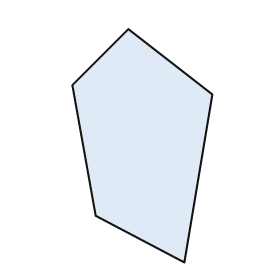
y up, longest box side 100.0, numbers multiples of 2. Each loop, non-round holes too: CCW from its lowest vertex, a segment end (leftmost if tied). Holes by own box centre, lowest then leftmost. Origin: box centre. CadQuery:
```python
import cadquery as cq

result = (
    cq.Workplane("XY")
    .moveTo(18.0, -50.0)
    .lineTo(30.0, 22.0)
    .lineTo(-6.0, 50.0)
    .lineTo(-30.0, 26.0)
    .lineTo(-20.0, -30.0)
    .close()
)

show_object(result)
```